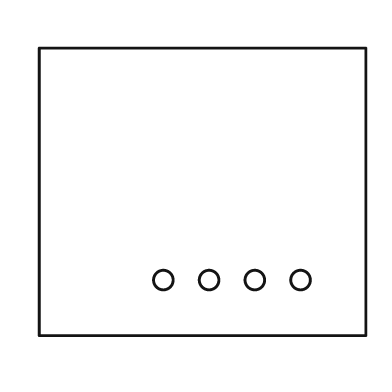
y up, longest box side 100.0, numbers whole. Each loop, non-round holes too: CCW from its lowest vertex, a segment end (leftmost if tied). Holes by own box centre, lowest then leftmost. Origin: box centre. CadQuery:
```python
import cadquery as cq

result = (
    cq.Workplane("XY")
    .moveTo(-50.0, -44.0)
    .lineTo(50.0, -44.0)
    .lineTo(50.0, 44.0)
    .lineTo(-50.0, 44.0)
    .close()
    .moveTo(-12.0, -27.0)
    .circle(3.0)
    .moveTo(2.0, -27.0)
    .circle(3.0)
    .moveTo(16.0, -27.0)
    .circle(3.0)
    .moveTo(30.0, -27.0)
    .circle(3.0)
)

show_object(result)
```